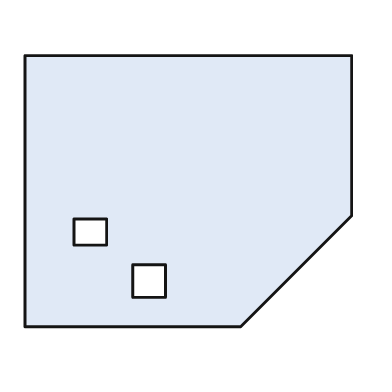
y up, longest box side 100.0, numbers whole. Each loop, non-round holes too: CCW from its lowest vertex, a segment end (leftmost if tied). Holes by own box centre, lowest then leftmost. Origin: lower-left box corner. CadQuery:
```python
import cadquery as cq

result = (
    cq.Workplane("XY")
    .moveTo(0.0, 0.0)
    .lineTo(66.0, 0.0)
    .lineTo(100.0, 34.0)
    .lineTo(100.0, 83.0)
    .lineTo(0.0, 83.0)
    .close()
    .moveTo(33.0, 9.0)
    .lineTo(43.0, 9.0)
    .lineTo(43.0, 19.0)
    .lineTo(33.0, 19.0)
    .close()
    .moveTo(15.0, 25.0)
    .lineTo(25.0, 25.0)
    .lineTo(25.0, 33.0)
    .lineTo(15.0, 33.0)
    .close()
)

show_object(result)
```